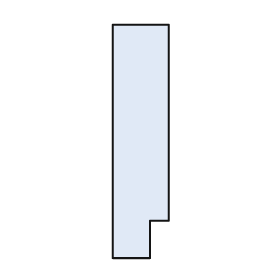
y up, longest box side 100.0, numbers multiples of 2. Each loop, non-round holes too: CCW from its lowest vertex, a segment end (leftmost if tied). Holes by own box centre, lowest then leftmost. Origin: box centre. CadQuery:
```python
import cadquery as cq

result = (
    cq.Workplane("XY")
    .moveTo(-12.0, -50.0)
    .lineTo(4.0, -50.0)
    .lineTo(4.0, -34.0)
    .lineTo(12.0, -34.0)
    .lineTo(12.0, 50.0)
    .lineTo(-12.0, 50.0)
    .close()
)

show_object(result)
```